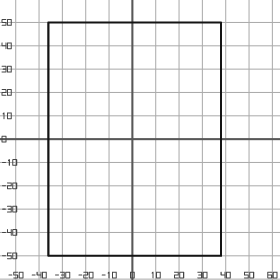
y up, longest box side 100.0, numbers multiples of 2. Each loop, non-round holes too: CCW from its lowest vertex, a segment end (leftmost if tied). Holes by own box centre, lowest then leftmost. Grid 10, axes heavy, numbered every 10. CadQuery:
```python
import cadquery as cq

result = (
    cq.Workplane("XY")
    .moveTo(-36.0, -50.0)
    .lineTo(38.0, -50.0)
    .lineTo(38.0, 50.0)
    .lineTo(-36.0, 50.0)
    .close()
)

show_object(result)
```